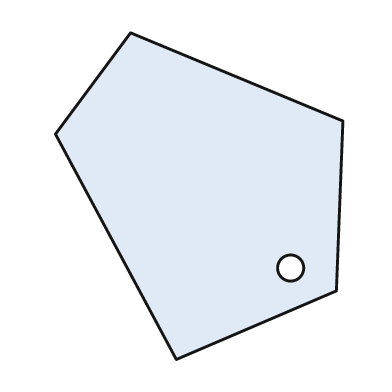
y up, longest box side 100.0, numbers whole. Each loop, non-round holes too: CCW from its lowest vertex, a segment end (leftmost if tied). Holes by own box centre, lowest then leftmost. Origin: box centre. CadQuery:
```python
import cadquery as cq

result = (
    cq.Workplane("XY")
    .moveTo(-7.0, -50.0)
    .lineTo(42.0, -29.0)
    .lineTo(44.0, 23.0)
    .lineTo(-21.0, 50.0)
    .lineTo(-44.0, 19.0)
    .close()
    .moveTo(28.0, -22.0)
    .circle(4.0)
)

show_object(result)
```